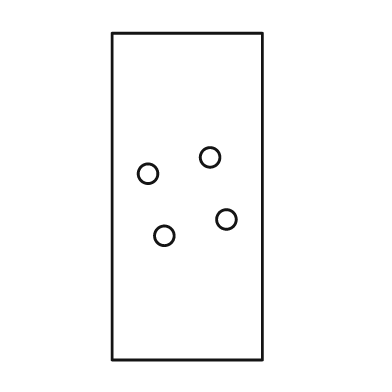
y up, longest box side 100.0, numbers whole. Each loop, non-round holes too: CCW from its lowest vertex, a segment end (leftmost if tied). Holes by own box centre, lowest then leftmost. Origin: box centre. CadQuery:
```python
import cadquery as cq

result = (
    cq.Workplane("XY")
    .moveTo(-23.0, -50.0)
    .lineTo(23.0, -50.0)
    .lineTo(23.0, 50.0)
    .lineTo(-23.0, 50.0)
    .close()
    .moveTo(-7.0, -12.0)
    .circle(3.0)
    .moveTo(12.0, -7.0)
    .circle(3.0)
    .moveTo(-12.0, 7.0)
    .circle(3.0)
    .moveTo(7.0, 12.0)
    .circle(3.0)
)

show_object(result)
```